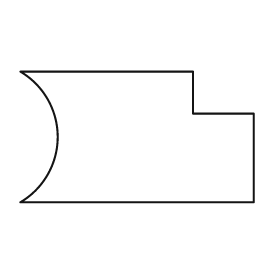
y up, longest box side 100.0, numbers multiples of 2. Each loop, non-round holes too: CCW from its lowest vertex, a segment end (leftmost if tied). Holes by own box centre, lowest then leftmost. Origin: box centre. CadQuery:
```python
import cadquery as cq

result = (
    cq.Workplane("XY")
    .moveTo(-50.0, -28.0)
    .lineTo(50.0, -28.0)
    .lineTo(50.0, 10.0)
    .lineTo(24.0, 10.0)
    .lineTo(24.0, 28.0)
    .lineTo(-50.0, 28.0)
    .threePointArc((-34.0, 0.0), (-50.0, -28.0))
    .close()
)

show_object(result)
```